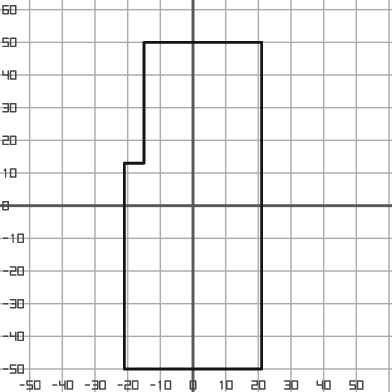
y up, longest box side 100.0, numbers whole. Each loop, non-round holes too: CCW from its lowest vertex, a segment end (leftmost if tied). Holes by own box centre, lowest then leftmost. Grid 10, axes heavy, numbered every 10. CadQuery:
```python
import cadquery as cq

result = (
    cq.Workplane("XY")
    .moveTo(-21.0, -50.0)
    .lineTo(21.0, -50.0)
    .lineTo(21.0, 50.0)
    .lineTo(-15.0, 50.0)
    .lineTo(-15.0, 13.0)
    .lineTo(-21.0, 13.0)
    .close()
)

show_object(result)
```